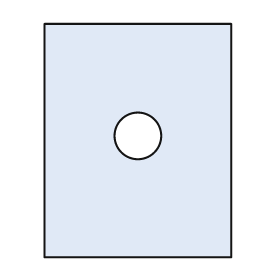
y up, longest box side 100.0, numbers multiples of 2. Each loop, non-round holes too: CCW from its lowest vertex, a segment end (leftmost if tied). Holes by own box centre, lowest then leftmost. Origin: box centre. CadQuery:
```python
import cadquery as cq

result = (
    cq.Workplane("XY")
    .moveTo(-40.0, -50.0)
    .lineTo(40.0, -50.0)
    .lineTo(40.0, 50.0)
    .lineTo(-40.0, 50.0)
    .close()
    .moveTo(0.0, 2.0)
    .circle(10.0)
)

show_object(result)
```